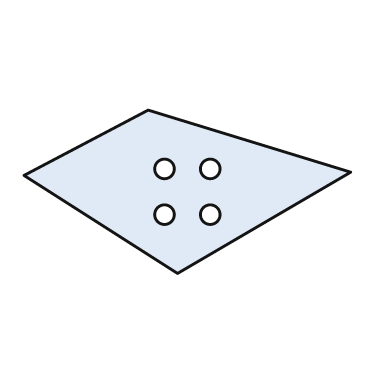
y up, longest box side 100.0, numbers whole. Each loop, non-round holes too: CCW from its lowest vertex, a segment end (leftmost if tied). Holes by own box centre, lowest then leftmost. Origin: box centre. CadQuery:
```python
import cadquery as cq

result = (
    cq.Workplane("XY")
    .moveTo(-3.0, -25.0)
    .lineTo(50.0, 6.0)
    .lineTo(-12.0, 25.0)
    .lineTo(-50.0, 5.0)
    .close()
    .moveTo(-7.0, -7.0)
    .circle(3.0)
    .moveTo(7.0, -7.0)
    .circle(3.0)
    .moveTo(-7.0, 7.0)
    .circle(3.0)
    .moveTo(7.0, 7.0)
    .circle(3.0)
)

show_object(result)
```